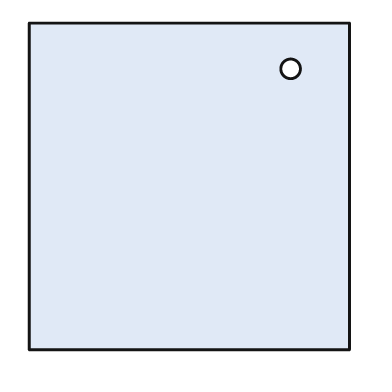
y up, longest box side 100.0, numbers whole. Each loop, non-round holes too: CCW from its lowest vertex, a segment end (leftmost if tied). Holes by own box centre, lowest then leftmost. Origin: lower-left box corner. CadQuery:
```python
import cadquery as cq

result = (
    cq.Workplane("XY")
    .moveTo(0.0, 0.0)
    .lineTo(98.0, 0.0)
    .lineTo(98.0, 100.0)
    .lineTo(0.0, 100.0)
    .close()
    .moveTo(80.0, 86.0)
    .circle(3.0)
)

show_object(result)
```